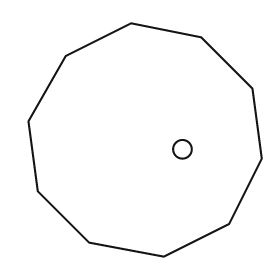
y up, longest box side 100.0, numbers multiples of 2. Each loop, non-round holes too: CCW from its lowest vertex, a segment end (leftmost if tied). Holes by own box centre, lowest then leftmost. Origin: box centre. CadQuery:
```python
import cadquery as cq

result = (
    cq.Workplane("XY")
    .moveTo(8.0, -50.0)
    .lineTo(36.0, -36.0)
    .lineTo(50.0, -8.0)
    .lineTo(46.0, 22.0)
    .lineTo(24.0, 44.0)
    .lineTo(-6.0, 50.0)
    .lineTo(-34.0, 36.0)
    .lineTo(-50.0, 8.0)
    .lineTo(-46.0, -22.0)
    .lineTo(-24.0, -44.0)
    .close()
    .moveTo(16.0, -4.0)
    .circle(4.0)
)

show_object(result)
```